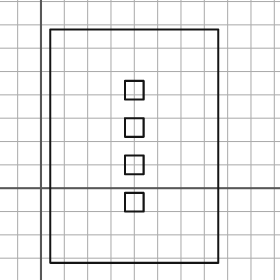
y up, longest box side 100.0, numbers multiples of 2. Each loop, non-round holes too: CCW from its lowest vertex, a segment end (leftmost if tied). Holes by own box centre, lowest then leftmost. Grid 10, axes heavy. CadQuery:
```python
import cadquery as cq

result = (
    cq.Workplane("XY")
    .moveTo(4.0, -32.0)
    .lineTo(76.0, -32.0)
    .lineTo(76.0, 68.0)
    .lineTo(4.0, 68.0)
    .close()
    .moveTo(36.0, -10.0)
    .lineTo(44.0, -10.0)
    .lineTo(44.0, -2.0)
    .lineTo(36.0, -2.0)
    .close()
    .moveTo(36.0, 6.0)
    .lineTo(44.0, 6.0)
    .lineTo(44.0, 14.0)
    .lineTo(36.0, 14.0)
    .close()
    .moveTo(36.0, 22.0)
    .lineTo(44.0, 22.0)
    .lineTo(44.0, 30.0)
    .lineTo(36.0, 30.0)
    .close()
    .moveTo(36.0, 38.0)
    .lineTo(44.0, 38.0)
    .lineTo(44.0, 46.0)
    .lineTo(36.0, 46.0)
    .close()
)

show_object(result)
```